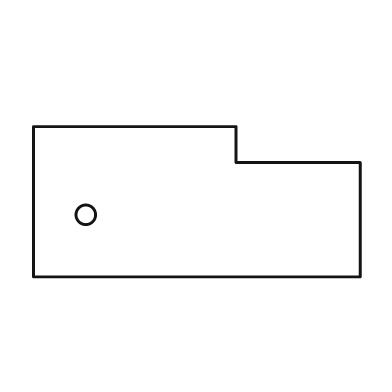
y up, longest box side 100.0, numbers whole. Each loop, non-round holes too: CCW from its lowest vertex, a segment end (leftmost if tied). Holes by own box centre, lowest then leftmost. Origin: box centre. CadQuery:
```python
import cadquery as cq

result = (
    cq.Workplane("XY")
    .moveTo(-50.0, -23.0)
    .lineTo(50.0, -23.0)
    .lineTo(50.0, 12.0)
    .lineTo(12.0, 12.0)
    .lineTo(12.0, 23.0)
    .lineTo(-50.0, 23.0)
    .close()
    .moveTo(-34.0, -4.0)
    .circle(3.0)
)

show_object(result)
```